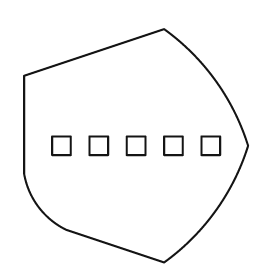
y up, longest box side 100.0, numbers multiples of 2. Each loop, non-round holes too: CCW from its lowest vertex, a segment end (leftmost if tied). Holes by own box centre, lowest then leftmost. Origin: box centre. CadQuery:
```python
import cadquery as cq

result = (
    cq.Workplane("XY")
    .moveTo(12.0, -50.0)
    .threePointArc((34.0, -28.0), (48.0, 0.0))
    .threePointArc((34.0, 28.0), (12.0, 50.0))
    .lineTo(-48.0, 30.0)
    .lineTo(-48.0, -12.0)
    .threePointArc((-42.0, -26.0), (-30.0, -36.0))
    .close()
    .moveTo(-36.0, -4.0)
    .lineTo(-28.0, -4.0)
    .lineTo(-28.0, 4.0)
    .lineTo(-36.0, 4.0)
    .close()
    .moveTo(-20.0, -4.0)
    .lineTo(-12.0, -4.0)
    .lineTo(-12.0, 4.0)
    .lineTo(-20.0, 4.0)
    .close()
    .moveTo(-4.0, -4.0)
    .lineTo(4.0, -4.0)
    .lineTo(4.0, 4.0)
    .lineTo(-4.0, 4.0)
    .close()
    .moveTo(12.0, -4.0)
    .lineTo(20.0, -4.0)
    .lineTo(20.0, 4.0)
    .lineTo(12.0, 4.0)
    .close()
    .moveTo(28.0, -4.0)
    .lineTo(36.0, -4.0)
    .lineTo(36.0, 4.0)
    .lineTo(28.0, 4.0)
    .close()
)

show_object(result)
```